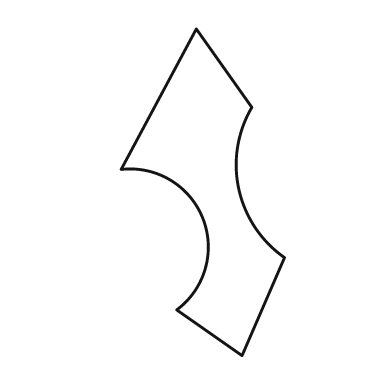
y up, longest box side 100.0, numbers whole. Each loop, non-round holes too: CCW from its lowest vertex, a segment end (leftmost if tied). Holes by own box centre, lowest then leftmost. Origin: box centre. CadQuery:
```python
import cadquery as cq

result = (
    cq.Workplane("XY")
    .moveTo(12.0, -50.0)
    .lineTo(25.0, -20.0)
    .threePointArc((11.0, 1.0), (15.0, 26.0))
    .lineTo(-2.0, 50.0)
    .lineTo(-25.0, 7.0)
    .threePointArc((0.0, -8.0), (-8.0, -36.0))
    .close()
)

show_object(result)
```